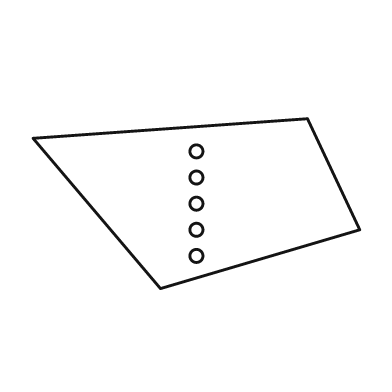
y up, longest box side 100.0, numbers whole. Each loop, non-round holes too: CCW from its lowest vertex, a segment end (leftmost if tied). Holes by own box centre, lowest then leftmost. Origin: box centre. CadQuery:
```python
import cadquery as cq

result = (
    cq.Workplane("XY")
    .moveTo(-11.0, -26.0)
    .lineTo(50.0, -8.0)
    .lineTo(34.0, 26.0)
    .lineTo(-50.0, 20.0)
    .close()
    .moveTo(0.0, -16.0)
    .circle(2.0)
    .moveTo(0.0, -8.0)
    .circle(2.0)
    .moveTo(0.0, 0.0)
    .circle(2.0)
    .moveTo(0.0, 8.0)
    .circle(2.0)
    .moveTo(0.0, 16.0)
    .circle(2.0)
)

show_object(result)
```